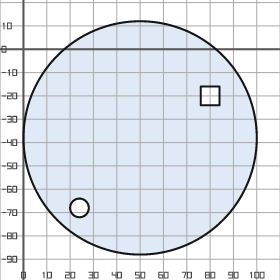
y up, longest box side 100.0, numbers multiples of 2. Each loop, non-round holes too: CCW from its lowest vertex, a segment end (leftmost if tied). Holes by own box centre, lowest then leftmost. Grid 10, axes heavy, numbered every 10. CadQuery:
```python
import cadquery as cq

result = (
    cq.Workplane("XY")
    .moveTo(50.0, -38.0)
    .circle(50.0)
    .moveTo(24.0, -68.0)
    .circle(4.0)
    .moveTo(76.0, -24.0)
    .lineTo(84.0, -24.0)
    .lineTo(84.0, -16.0)
    .lineTo(76.0, -16.0)
    .close()
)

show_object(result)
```